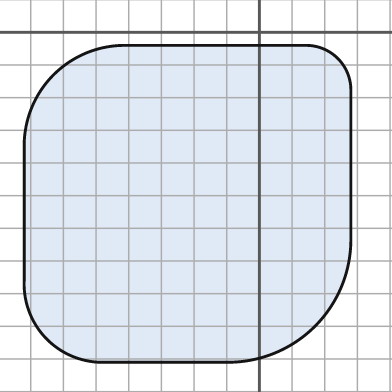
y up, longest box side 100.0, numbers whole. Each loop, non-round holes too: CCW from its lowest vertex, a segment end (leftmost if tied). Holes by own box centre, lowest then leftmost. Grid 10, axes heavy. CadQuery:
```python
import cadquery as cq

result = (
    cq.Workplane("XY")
    .moveTo(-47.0, -101.0)
    .lineTo(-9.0, -101.0)
    .threePointArc((17.0, -90.0), (28.0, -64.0))
    .lineTo(28.0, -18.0)
    .threePointArc((24.0, -8.0), (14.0, -4.0))
    .lineTo(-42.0, -4.0)
    .threePointArc((-63.0, -13.0), (-72.0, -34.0))
    .lineTo(-72.0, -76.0)
    .threePointArc((-65.0, -94.0), (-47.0, -101.0))
    .close()
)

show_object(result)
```